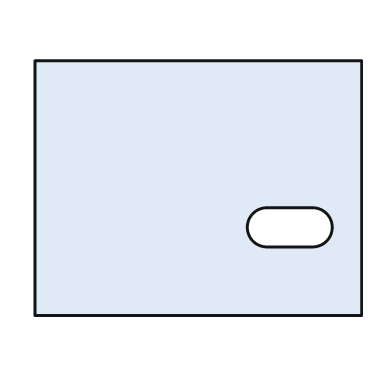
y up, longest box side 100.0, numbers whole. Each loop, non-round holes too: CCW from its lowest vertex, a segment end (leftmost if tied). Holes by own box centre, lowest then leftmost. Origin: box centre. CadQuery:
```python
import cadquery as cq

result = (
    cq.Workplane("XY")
    .moveTo(-50.0, -39.0)
    .lineTo(50.0, -39.0)
    .lineTo(50.0, 39.0)
    .lineTo(-50.0, 39.0)
    .close()
    .moveTo(21.0, -18.0)
    .lineTo(35.0, -18.0)
    .threePointArc((41.0, -12.0), (35.0, -6.0))
    .lineTo(21.0, -6.0)
    .threePointArc((15.0, -12.0), (21.0, -18.0))
    .close()
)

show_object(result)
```